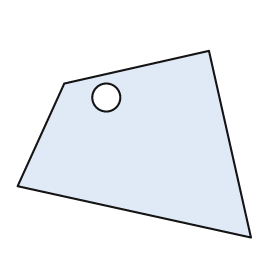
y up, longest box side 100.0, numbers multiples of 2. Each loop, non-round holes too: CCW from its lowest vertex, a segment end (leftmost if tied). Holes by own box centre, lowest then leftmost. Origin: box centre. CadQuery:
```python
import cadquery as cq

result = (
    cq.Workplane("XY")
    .moveTo(50.0, -40.0)
    .lineTo(32.0, 40.0)
    .lineTo(-30.0, 26.0)
    .lineTo(-50.0, -18.0)
    .close()
    .moveTo(-12.0, 20.0)
    .circle(6.0)
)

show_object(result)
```